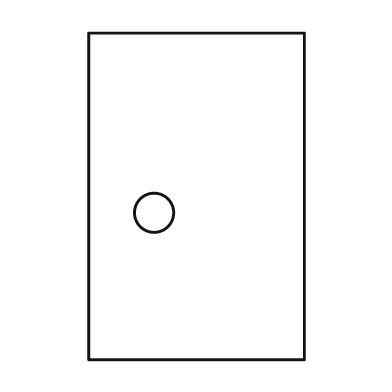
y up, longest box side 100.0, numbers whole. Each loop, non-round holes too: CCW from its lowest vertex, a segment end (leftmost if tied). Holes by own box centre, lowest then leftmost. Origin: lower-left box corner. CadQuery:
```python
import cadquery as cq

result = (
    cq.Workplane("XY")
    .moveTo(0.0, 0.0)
    .lineTo(66.0, 0.0)
    .lineTo(66.0, 100.0)
    .lineTo(0.0, 100.0)
    .close()
    .moveTo(20.0, 45.0)
    .circle(6.0)
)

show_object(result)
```